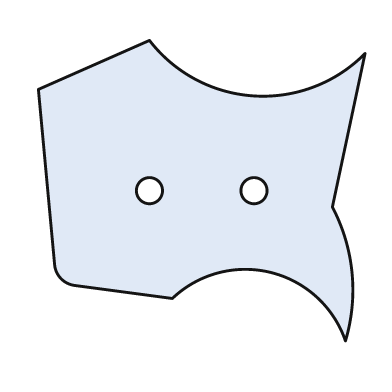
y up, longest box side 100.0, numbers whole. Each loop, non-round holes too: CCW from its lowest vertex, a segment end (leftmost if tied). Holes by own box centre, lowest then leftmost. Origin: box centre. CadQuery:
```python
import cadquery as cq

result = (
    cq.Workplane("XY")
    .moveTo(44.0, -46.0)
    .threePointArc((46.0, -25.0), (40.0, -5.0))
    .lineTo(50.0, 42.0)
    .threePointArc((16.0, 29.0), (-16.0, 46.0))
    .lineTo(-50.0, 31.0)
    .lineTo(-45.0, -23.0)
    .threePointArc((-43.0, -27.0), (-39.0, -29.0))
    .lineTo(-9.0, -33.0)
    .threePointArc((21.0, -25.0), (44.0, -46.0))
    .close()
    .moveTo(-16.0, 0.0)
    .circle(4.0)
    .moveTo(16.0, 0.0)
    .circle(4.0)
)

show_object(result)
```